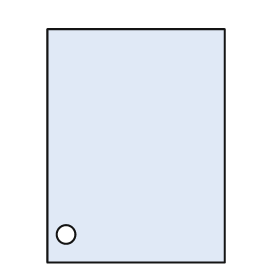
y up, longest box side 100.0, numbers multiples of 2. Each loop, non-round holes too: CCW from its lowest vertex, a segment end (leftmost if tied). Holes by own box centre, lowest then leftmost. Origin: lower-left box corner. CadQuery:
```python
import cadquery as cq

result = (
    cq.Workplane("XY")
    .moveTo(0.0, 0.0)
    .lineTo(76.0, 0.0)
    .lineTo(76.0, 100.0)
    .lineTo(0.0, 100.0)
    .close()
    .moveTo(8.0, 12.0)
    .circle(4.0)
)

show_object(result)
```